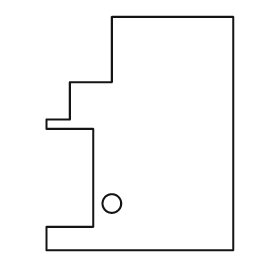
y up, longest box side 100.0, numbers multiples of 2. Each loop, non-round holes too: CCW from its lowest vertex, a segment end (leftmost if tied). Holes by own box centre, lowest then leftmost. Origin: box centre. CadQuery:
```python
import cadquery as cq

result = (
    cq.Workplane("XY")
    .moveTo(-40.0, -50.0)
    .lineTo(40.0, -50.0)
    .lineTo(40.0, 50.0)
    .lineTo(-12.0, 50.0)
    .lineTo(-12.0, 22.0)
    .lineTo(-30.0, 22.0)
    .lineTo(-30.0, 6.0)
    .lineTo(-40.0, 6.0)
    .lineTo(-40.0, 2.0)
    .lineTo(-20.0, 2.0)
    .lineTo(-20.0, -40.0)
    .lineTo(-40.0, -40.0)
    .close()
    .moveTo(-12.0, -30.0)
    .circle(4.0)
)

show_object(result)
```